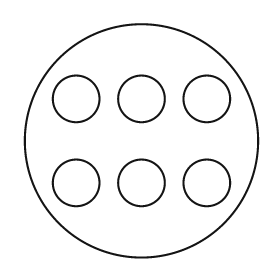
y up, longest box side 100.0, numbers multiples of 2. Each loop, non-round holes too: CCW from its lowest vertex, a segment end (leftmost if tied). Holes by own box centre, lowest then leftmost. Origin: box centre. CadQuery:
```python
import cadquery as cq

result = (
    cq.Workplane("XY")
    .moveTo(0.0, 0.0)
    .circle(50.0)
    .moveTo(-28.0, -18.0)
    .circle(10.0)
    .moveTo(0.0, -18.0)
    .circle(10.0)
    .moveTo(28.0, -18.0)
    .circle(10.0)
    .moveTo(-28.0, 18.0)
    .circle(10.0)
    .moveTo(0.0, 18.0)
    .circle(10.0)
    .moveTo(28.0, 18.0)
    .circle(10.0)
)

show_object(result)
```